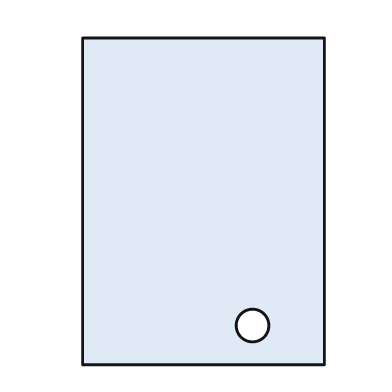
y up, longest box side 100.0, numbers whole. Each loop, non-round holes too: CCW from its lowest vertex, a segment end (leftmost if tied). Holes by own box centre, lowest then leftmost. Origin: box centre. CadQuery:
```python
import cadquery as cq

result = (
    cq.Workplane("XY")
    .moveTo(-37.0, -50.0)
    .lineTo(37.0, -50.0)
    .lineTo(37.0, 50.0)
    .lineTo(-37.0, 50.0)
    .close()
    .moveTo(15.0, -38.0)
    .circle(5.0)
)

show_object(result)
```